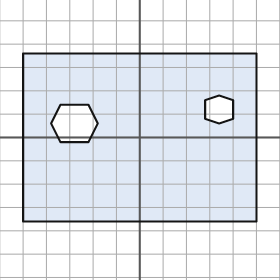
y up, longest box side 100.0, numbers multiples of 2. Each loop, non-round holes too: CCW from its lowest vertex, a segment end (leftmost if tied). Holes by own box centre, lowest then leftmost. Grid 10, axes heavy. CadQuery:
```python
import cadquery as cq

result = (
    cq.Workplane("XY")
    .moveTo(-50.0, -36.0)
    .lineTo(50.0, -36.0)
    .lineTo(50.0, 36.0)
    .lineTo(-50.0, 36.0)
    .close()
    .moveTo(-34.0, -2.0)
    .lineTo(-22.0, -2.0)
    .lineTo(-18.0, 6.0)
    .lineTo(-22.0, 14.0)
    .lineTo(-34.0, 14.0)
    .lineTo(-38.0, 6.0)
    .close()
    .moveTo(34.0, 6.0)
    .lineTo(40.0, 8.0)
    .lineTo(40.0, 16.0)
    .lineTo(34.0, 18.0)
    .lineTo(28.0, 16.0)
    .lineTo(28.0, 8.0)
    .close()
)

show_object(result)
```